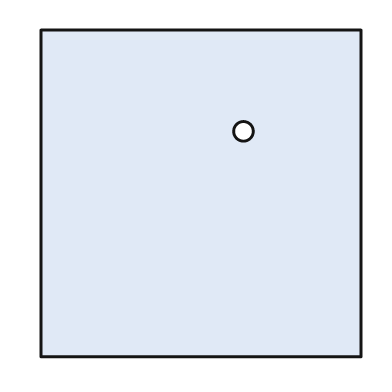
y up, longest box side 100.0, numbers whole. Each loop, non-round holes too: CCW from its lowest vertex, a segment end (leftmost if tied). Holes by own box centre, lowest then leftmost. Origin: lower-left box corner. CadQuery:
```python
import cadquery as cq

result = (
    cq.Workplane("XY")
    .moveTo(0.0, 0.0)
    .lineTo(98.0, 0.0)
    .lineTo(98.0, 100.0)
    .lineTo(0.0, 100.0)
    .close()
    .moveTo(62.0, 69.0)
    .circle(3.0)
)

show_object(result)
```